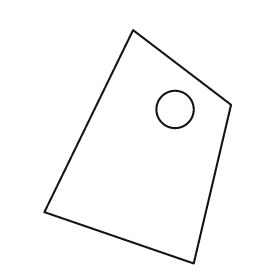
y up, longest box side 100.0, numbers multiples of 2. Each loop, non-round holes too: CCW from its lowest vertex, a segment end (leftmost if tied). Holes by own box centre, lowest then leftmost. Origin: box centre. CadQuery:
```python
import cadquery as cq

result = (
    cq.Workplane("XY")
    .moveTo(24.0, -50.0)
    .lineTo(40.0, 18.0)
    .lineTo(-2.0, 50.0)
    .lineTo(-40.0, -28.0)
    .close()
    .moveTo(16.0, 16.0)
    .circle(8.0)
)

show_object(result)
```